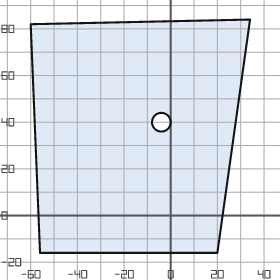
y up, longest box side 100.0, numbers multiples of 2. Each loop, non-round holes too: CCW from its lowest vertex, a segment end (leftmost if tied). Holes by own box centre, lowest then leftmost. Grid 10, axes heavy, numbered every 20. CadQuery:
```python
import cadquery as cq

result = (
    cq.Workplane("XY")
    .moveTo(-56.0, -16.0)
    .lineTo(20.0, -16.0)
    .lineTo(34.0, 84.0)
    .lineTo(-60.0, 82.0)
    .close()
    .moveTo(-4.0, 40.0)
    .circle(4.0)
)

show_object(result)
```